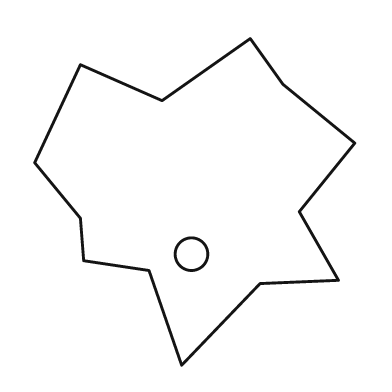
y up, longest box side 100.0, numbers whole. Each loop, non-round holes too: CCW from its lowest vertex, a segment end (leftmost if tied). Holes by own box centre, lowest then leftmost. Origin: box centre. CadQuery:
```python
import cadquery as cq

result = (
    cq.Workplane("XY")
    .moveTo(-4.0, -50.0)
    .lineTo(20.0, -25.0)
    .lineTo(44.0, -24.0)
    .lineTo(32.0, -3.0)
    .lineTo(49.0, 18.0)
    .lineTo(27.0, 36.0)
    .lineTo(17.0, 50.0)
    .lineTo(-10.0, 31.0)
    .lineTo(-35.0, 42.0)
    .lineTo(-49.0, 12.0)
    .lineTo(-35.0, -5.0)
    .lineTo(-34.0, -18.0)
    .lineTo(-14.0, -21.0)
    .close()
    .moveTo(-1.0, -16.0)
    .circle(5.0)
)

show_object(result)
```